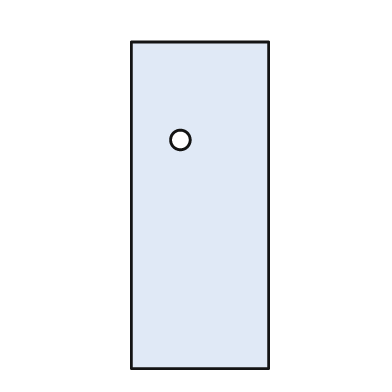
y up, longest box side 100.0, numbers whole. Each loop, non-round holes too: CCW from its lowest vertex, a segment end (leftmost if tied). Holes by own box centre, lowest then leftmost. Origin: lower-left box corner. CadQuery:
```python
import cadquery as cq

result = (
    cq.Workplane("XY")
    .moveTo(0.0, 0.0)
    .lineTo(42.0, 0.0)
    .lineTo(42.0, 100.0)
    .lineTo(0.0, 100.0)
    .close()
    .moveTo(15.0, 70.0)
    .circle(3.0)
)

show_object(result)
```